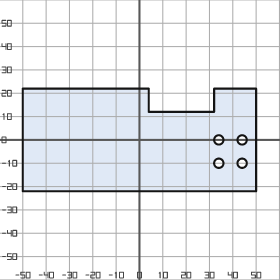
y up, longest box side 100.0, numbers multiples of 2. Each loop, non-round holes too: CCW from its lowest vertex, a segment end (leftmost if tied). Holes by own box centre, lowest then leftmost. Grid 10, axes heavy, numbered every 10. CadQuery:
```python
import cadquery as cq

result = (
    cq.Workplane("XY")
    .moveTo(-50.0, -22.0)
    .lineTo(50.0, -22.0)
    .lineTo(50.0, 22.0)
    .lineTo(32.0, 22.0)
    .lineTo(32.0, 12.0)
    .lineTo(4.0, 12.0)
    .lineTo(4.0, 22.0)
    .lineTo(-50.0, 22.0)
    .close()
    .moveTo(34.0, -10.0)
    .circle(2.0)
    .moveTo(44.0, -10.0)
    .circle(2.0)
    .moveTo(34.0, 0.0)
    .circle(2.0)
    .moveTo(44.0, 0.0)
    .circle(2.0)
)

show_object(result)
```